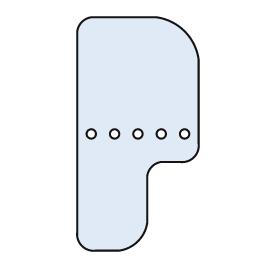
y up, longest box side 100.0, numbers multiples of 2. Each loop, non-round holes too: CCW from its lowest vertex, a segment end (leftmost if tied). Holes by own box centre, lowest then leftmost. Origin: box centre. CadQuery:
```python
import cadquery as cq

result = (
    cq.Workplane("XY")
    .moveTo(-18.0, -50.0)
    .lineTo(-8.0, -50.0)
    .threePointArc((0.0, -46.0), (4.0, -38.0))
    .lineTo(4.0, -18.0)
    .threePointArc((6.0, -14.0), (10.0, -12.0))
    .lineTo(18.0, -12.0)
    .threePointArc((24.0, -10.0), (26.0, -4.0))
    .lineTo(26.0, 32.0)
    .threePointArc((20.0, 44.0), (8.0, 50.0))
    .lineTo(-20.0, 50.0)
    .threePointArc((-24.0, 48.0), (-26.0, 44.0))
    .lineTo(-26.0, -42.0)
    .threePointArc((-24.0, -48.0), (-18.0, -50.0))
    .close()
    .moveTo(-20.0, 0.0)
    .circle(2.0)
    .moveTo(-10.0, 0.0)
    .circle(2.0)
    .moveTo(0.0, 0.0)
    .circle(2.0)
    .moveTo(10.0, 0.0)
    .circle(2.0)
    .moveTo(20.0, 0.0)
    .circle(2.0)
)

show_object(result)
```